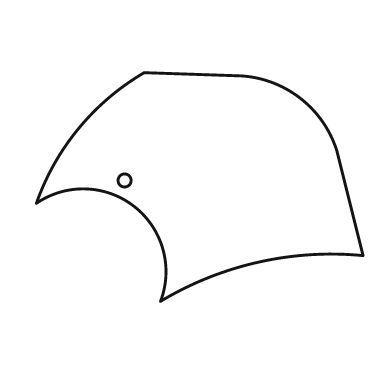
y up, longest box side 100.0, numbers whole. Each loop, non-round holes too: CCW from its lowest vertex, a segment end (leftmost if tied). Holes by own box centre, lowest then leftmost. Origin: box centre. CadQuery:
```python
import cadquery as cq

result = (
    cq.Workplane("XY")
    .moveTo(-12.0, -35.0)
    .threePointArc((18.0, -23.0), (50.0, -21.0))
    .lineTo(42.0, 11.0)
    .threePointArc((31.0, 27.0), (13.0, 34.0))
    .lineTo(-17.0, 35.0)
    .threePointArc((-37.0, 18.0), (-50.0, -5.0))
    .threePointArc((-20.0, -6.0), (-12.0, -35.0))
    .close()
    .moveTo(-23.0, 2.0)
    .circle(2.0)
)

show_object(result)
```